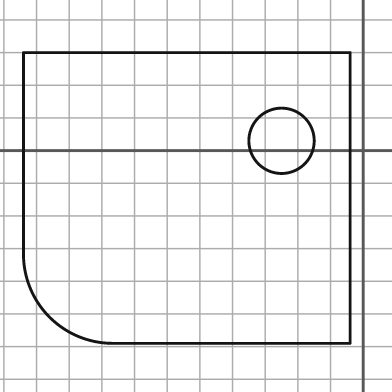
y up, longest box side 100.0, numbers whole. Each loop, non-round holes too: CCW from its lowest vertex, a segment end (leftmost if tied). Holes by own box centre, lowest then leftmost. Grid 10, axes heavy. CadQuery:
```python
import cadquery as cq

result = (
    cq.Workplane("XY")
    .moveTo(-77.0, -59.0)
    .lineTo(-4.0, -59.0)
    .lineTo(-4.0, 30.0)
    .lineTo(-104.0, 30.0)
    .lineTo(-104.0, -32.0)
    .threePointArc((-96.0, -51.0), (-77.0, -59.0))
    .close()
    .moveTo(-25.0, 3.0)
    .circle(10.0)
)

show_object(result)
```